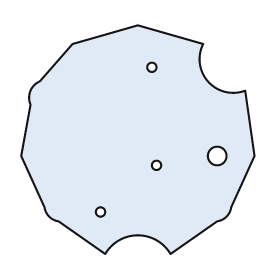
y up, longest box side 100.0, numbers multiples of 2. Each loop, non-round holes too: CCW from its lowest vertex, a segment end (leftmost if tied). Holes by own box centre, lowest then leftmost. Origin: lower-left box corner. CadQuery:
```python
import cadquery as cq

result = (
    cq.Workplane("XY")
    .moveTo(36.0, 0.0)
    .threePointArc((50.0, 8.0), (64.0, 0.0))
    .lineTo(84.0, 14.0)
    .threePointArc((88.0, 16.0), (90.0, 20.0))
    .lineTo(100.0, 42.0)
    .lineTo(96.0, 70.0)
    .threePointArc((80.0, 74.0), (78.0, 90.0))
    .lineTo(50.0, 98.0)
    .lineTo(22.0, 90.0)
    .lineTo(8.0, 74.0)
    .threePointArc((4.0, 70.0), (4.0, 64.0))
    .lineTo(0.0, 42.0)
    .lineTo(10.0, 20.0)
    .threePointArc((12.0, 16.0), (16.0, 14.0))
    .close()
    .moveTo(34.0, 18.0)
    .circle(2.0)
    .moveTo(58.0, 38.0)
    .circle(2.0)
    .moveTo(84.0, 42.0)
    .circle(4.0)
    .moveTo(56.0, 80.0)
    .circle(2.0)
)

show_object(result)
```